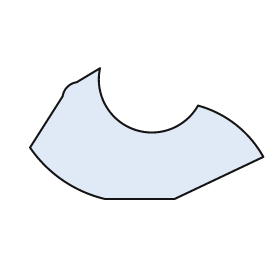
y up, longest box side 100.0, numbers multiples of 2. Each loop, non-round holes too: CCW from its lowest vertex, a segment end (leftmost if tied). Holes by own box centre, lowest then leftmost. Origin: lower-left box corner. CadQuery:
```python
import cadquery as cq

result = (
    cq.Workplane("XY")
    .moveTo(32.0, 0.0)
    .lineTo(62.0, 0.0)
    .lineTo(100.0, 18.0)
    .threePointArc((88.0, 32.0), (72.0, 40.0))
    .threePointArc((44.0, 30.0), (30.0, 56.0))
    .lineTo(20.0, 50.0)
    .threePointArc((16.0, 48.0), (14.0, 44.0))
    .lineTo(0.0, 22.0)
    .threePointArc((14.0, 8.0), (32.0, 0.0))
    .close()
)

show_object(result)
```